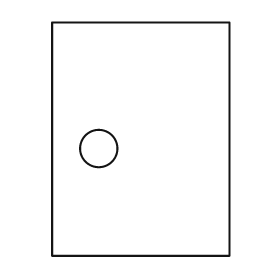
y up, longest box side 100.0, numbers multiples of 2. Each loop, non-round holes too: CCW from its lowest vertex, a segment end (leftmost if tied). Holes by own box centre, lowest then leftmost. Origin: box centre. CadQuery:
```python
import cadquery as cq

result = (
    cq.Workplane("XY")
    .moveTo(-38.0, -50.0)
    .lineTo(38.0, -50.0)
    .lineTo(38.0, 50.0)
    .lineTo(-38.0, 50.0)
    .close()
    .moveTo(-18.0, -4.0)
    .circle(8.0)
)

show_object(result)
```